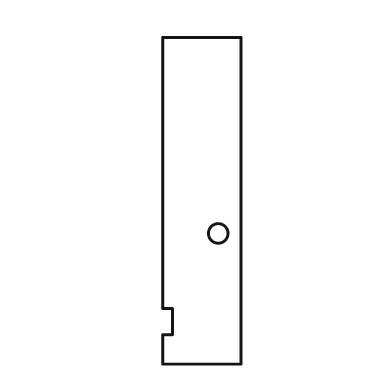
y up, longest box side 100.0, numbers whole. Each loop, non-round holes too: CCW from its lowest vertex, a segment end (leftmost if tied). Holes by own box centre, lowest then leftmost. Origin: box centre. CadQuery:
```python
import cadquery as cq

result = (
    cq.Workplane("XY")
    .moveTo(-12.0, -50.0)
    .lineTo(12.0, -50.0)
    .lineTo(12.0, 50.0)
    .lineTo(-12.0, 50.0)
    .lineTo(-12.0, -33.0)
    .lineTo(-9.0, -33.0)
    .lineTo(-9.0, -41.0)
    .lineTo(-12.0, -41.0)
    .close()
    .moveTo(5.0, -10.0)
    .circle(3.0)
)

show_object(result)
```